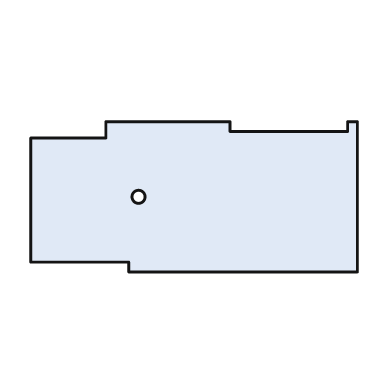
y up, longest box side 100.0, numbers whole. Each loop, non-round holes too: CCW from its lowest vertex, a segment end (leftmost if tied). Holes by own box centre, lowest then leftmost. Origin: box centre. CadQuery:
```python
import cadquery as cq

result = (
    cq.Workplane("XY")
    .moveTo(-20.0, -23.0)
    .lineTo(50.0, -23.0)
    .lineTo(50.0, 23.0)
    .lineTo(47.0, 23.0)
    .lineTo(47.0, 20.0)
    .lineTo(11.0, 20.0)
    .lineTo(11.0, 23.0)
    .lineTo(-27.0, 23.0)
    .lineTo(-27.0, 18.0)
    .lineTo(-50.0, 18.0)
    .lineTo(-50.0, -20.0)
    .lineTo(-20.0, -20.0)
    .close()
    .moveTo(-17.0, 0.0)
    .circle(2.0)
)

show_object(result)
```